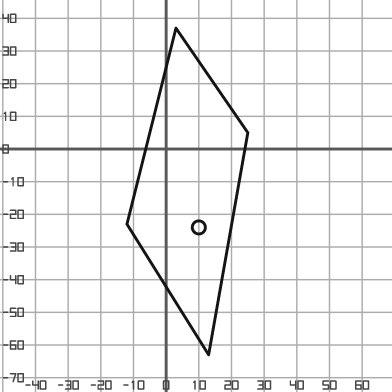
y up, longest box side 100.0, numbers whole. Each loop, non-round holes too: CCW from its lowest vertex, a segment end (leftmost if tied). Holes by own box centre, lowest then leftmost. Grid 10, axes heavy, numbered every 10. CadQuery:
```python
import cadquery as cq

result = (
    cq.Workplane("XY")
    .moveTo(13.0, -63.0)
    .lineTo(25.0, 5.0)
    .lineTo(3.0, 37.0)
    .lineTo(-12.0, -23.0)
    .close()
    .moveTo(10.0, -24.0)
    .circle(2.0)
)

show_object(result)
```